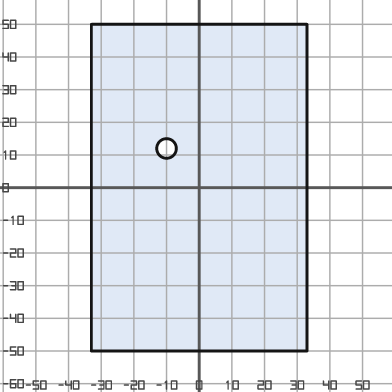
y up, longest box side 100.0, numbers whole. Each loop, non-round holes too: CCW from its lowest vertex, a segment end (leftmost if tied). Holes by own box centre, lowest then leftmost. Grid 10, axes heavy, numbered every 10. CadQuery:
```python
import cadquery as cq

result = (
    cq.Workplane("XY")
    .moveTo(-33.0, -50.0)
    .lineTo(33.0, -50.0)
    .lineTo(33.0, 50.0)
    .lineTo(-33.0, 50.0)
    .close()
    .moveTo(-10.0, 12.0)
    .circle(3.0)
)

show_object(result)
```